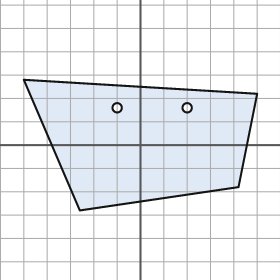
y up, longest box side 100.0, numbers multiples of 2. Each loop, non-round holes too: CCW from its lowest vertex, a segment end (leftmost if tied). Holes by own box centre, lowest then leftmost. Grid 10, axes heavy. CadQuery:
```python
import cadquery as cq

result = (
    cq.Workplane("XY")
    .moveTo(-26.0, -28.0)
    .lineTo(42.0, -18.0)
    .lineTo(50.0, 22.0)
    .lineTo(-50.0, 28.0)
    .close()
    .moveTo(-10.0, 16.0)
    .circle(2.0)
    .moveTo(20.0, 16.0)
    .circle(2.0)
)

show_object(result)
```